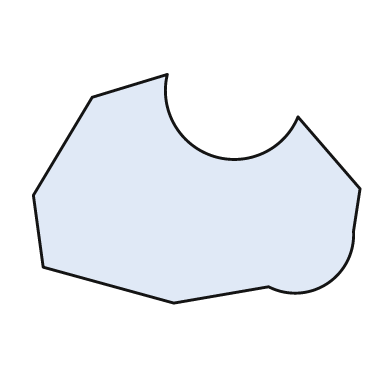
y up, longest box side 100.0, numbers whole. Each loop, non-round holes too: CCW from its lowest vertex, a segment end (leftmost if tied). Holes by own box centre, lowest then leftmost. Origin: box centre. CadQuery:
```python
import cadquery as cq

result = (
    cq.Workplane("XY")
    .moveTo(-7.0, -35.0)
    .lineTo(22.0, -30.0)
    .threePointArc((40.0, -29.0), (48.0, -13.0))
    .lineTo(50.0, 0.0)
    .lineTo(31.0, 22.0)
    .threePointArc((5.0, 10.0), (-9.0, 35.0))
    .lineTo(-32.0, 28.0)
    .lineTo(-50.0, -2.0)
    .lineTo(-47.0, -24.0)
    .close()
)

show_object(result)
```